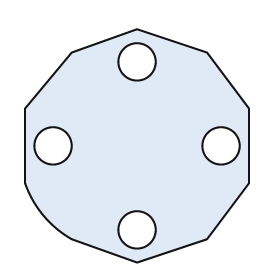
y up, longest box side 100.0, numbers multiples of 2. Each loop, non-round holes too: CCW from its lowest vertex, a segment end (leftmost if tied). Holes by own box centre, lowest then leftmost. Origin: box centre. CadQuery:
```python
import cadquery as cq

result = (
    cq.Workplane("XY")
    .moveTo(0.0, -50.0)
    .lineTo(30.0, -40.0)
    .lineTo(48.0, -16.0)
    .lineTo(48.0, 16.0)
    .lineTo(30.0, 40.0)
    .lineTo(0.0, 50.0)
    .lineTo(-28.0, 40.0)
    .lineTo(-48.0, 16.0)
    .lineTo(-48.0, -16.0)
    .threePointArc((-40.0, -30.0), (-28.0, -40.0))
    .close()
    .moveTo(0.0, -36.0)
    .circle(8.0)
    .moveTo(-36.0, 0.0)
    .circle(8.0)
    .moveTo(36.0, 0.0)
    .circle(8.0)
    .moveTo(0.0, 36.0)
    .circle(8.0)
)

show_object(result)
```